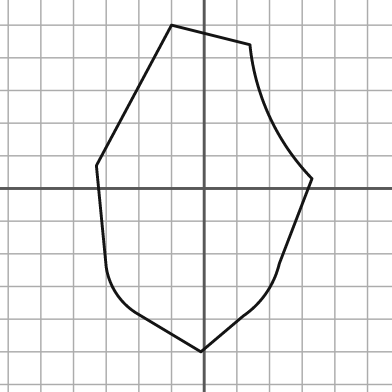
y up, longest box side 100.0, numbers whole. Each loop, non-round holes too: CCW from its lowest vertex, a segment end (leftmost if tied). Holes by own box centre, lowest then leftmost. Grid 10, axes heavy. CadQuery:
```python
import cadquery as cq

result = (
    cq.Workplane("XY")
    .moveTo(-1.0, -50.0)
    .lineTo(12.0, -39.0)
    .threePointArc((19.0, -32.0), (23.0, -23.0))
    .lineTo(33.0, 3.0)
    .threePointArc((20.0, 22.0), (14.0, 44.0))
    .lineTo(-10.0, 50.0)
    .lineTo(-33.0, 7.0)
    .lineTo(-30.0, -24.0)
    .threePointArc((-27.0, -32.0), (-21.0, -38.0))
    .close()
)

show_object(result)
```